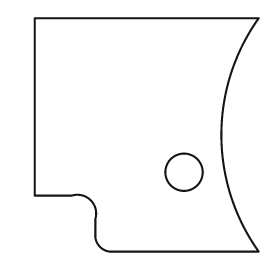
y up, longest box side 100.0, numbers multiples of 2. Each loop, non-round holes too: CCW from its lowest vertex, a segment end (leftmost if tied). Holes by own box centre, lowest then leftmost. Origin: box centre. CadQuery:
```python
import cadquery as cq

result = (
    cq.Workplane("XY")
    .moveTo(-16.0, -50.0)
    .lineTo(48.0, -50.0)
    .threePointArc((32.0, 0.0), (48.0, 50.0))
    .lineTo(-48.0, 50.0)
    .lineTo(-48.0, -26.0)
    .lineTo(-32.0, -26.0)
    .threePointArc((-24.0, -28.0), (-22.0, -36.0))
    .lineTo(-22.0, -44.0)
    .threePointArc((-20.0, -48.0), (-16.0, -50.0))
    .close()
    .moveTo(16.0, -16.0)
    .circle(8.0)
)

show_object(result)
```